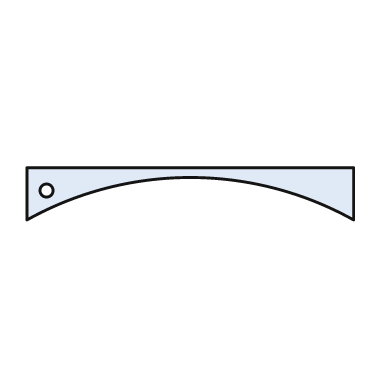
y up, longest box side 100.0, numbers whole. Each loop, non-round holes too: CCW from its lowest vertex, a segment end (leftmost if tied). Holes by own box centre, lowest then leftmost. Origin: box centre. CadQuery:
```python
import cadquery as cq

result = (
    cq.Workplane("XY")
    .moveTo(-50.0, -8.0)
    .threePointArc((0.0, 5.0), (50.0, -8.0))
    .lineTo(50.0, 8.0)
    .lineTo(-50.0, 8.0)
    .close()
    .moveTo(-44.0, 1.0)
    .circle(2.0)
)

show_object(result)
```